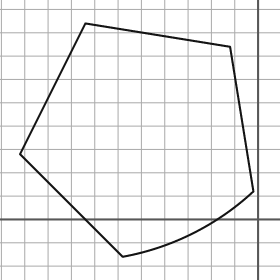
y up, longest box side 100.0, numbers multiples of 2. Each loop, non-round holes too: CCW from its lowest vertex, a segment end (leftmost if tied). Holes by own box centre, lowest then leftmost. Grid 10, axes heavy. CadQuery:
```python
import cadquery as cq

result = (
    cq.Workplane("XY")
    .moveTo(-58.0, -16.0)
    .threePointArc((-28.0, -6.0), (-2.0, 12.0))
    .lineTo(-12.0, 74.0)
    .lineTo(-74.0, 84.0)
    .lineTo(-102.0, 28.0)
    .close()
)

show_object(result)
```